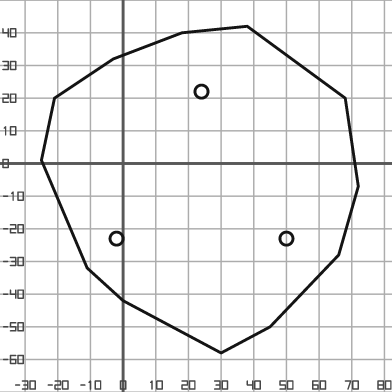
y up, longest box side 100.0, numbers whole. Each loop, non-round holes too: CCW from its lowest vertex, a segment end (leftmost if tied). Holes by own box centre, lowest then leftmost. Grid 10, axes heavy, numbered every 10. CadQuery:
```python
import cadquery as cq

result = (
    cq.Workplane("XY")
    .moveTo(30.0, -58.0)
    .lineTo(45.0, -50.0)
    .lineTo(66.0, -28.0)
    .lineTo(72.0, -7.0)
    .lineTo(68.0, 20.0)
    .lineTo(38.0, 42.0)
    .lineTo(18.0, 40.0)
    .lineTo(-3.0, 32.0)
    .lineTo(-21.0, 20.0)
    .lineTo(-25.0, 1.0)
    .lineTo(-11.0, -32.0)
    .lineTo(0.0, -42.0)
    .close()
    .moveTo(-2.0, -23.0)
    .circle(2.0)
    .moveTo(50.0, -23.0)
    .circle(2.0)
    .moveTo(24.0, 22.0)
    .circle(2.0)
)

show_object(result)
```